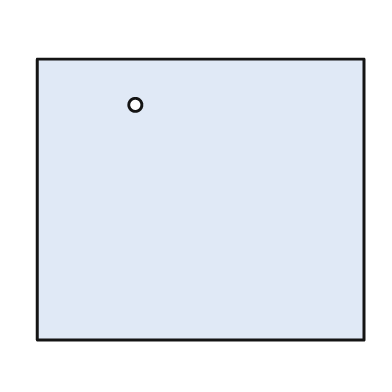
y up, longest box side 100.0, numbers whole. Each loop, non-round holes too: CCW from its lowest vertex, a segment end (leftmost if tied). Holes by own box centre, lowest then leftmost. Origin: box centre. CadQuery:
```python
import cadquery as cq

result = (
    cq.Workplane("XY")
    .moveTo(-50.0, -43.0)
    .lineTo(50.0, -43.0)
    .lineTo(50.0, 43.0)
    .lineTo(-50.0, 43.0)
    .close()
    .moveTo(-20.0, 29.0)
    .circle(2.0)
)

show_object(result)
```